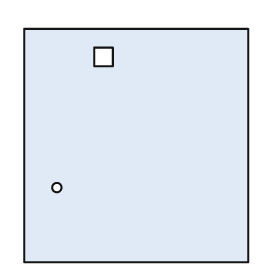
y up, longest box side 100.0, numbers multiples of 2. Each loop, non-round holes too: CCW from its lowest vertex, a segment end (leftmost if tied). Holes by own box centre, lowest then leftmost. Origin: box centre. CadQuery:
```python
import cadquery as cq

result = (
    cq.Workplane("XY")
    .moveTo(-48.0, -50.0)
    .lineTo(48.0, -50.0)
    .lineTo(48.0, 50.0)
    .lineTo(-48.0, 50.0)
    .close()
    .moveTo(-34.0, -18.0)
    .circle(2.0)
    .moveTo(-18.0, 34.0)
    .lineTo(-10.0, 34.0)
    .lineTo(-10.0, 42.0)
    .lineTo(-18.0, 42.0)
    .close()
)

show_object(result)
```